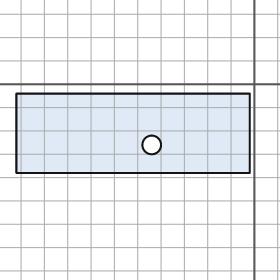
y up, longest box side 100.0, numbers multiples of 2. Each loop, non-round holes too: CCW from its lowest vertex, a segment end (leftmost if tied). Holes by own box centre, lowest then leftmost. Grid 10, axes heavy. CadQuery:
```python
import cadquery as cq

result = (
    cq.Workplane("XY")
    .moveTo(-102.0, -38.0)
    .lineTo(-2.0, -38.0)
    .lineTo(-2.0, -4.0)
    .lineTo(-102.0, -4.0)
    .close()
    .moveTo(-44.0, -26.0)
    .circle(4.0)
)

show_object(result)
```